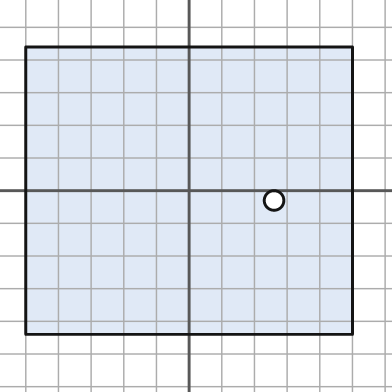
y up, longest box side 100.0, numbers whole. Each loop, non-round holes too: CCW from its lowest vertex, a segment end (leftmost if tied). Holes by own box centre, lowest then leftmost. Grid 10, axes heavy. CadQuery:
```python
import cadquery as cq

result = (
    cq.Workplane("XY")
    .moveTo(-50.0, -44.0)
    .lineTo(50.0, -44.0)
    .lineTo(50.0, 44.0)
    .lineTo(-50.0, 44.0)
    .close()
    .moveTo(26.0, -3.0)
    .circle(3.0)
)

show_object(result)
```